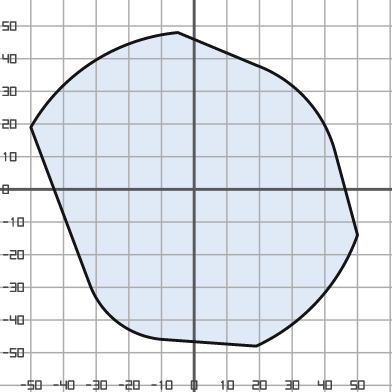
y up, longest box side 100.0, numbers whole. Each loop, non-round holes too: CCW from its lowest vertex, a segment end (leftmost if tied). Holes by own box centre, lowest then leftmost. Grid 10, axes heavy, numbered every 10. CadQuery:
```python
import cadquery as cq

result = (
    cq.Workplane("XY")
    .moveTo(19.0, -48.0)
    .threePointArc((38.0, -34.0), (50.0, -14.0))
    .lineTo(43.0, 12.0)
    .threePointArc((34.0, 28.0), (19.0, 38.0))
    .lineTo(-5.0, 48.0)
    .threePointArc((-31.0, 39.0), (-50.0, 19.0))
    .lineTo(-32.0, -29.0)
    .threePointArc((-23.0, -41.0), (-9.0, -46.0))
    .close()
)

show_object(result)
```